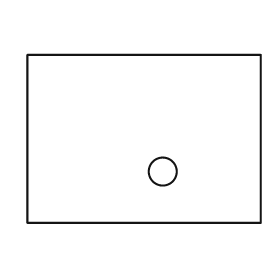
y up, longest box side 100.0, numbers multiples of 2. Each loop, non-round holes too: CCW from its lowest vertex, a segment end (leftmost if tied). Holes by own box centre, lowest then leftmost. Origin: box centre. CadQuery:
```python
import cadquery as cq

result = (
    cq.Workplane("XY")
    .moveTo(-50.0, -36.0)
    .lineTo(50.0, -36.0)
    .lineTo(50.0, 36.0)
    .lineTo(-50.0, 36.0)
    .close()
    .moveTo(8.0, -14.0)
    .circle(6.0)
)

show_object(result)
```